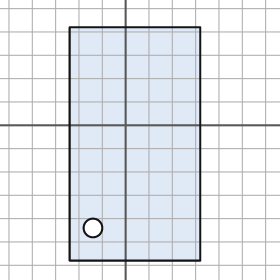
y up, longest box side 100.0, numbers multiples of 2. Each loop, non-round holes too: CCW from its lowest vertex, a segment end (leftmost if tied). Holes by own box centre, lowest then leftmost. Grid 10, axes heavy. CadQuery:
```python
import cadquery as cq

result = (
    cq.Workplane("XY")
    .moveTo(-24.0, -58.0)
    .lineTo(32.0, -58.0)
    .lineTo(32.0, 42.0)
    .lineTo(-24.0, 42.0)
    .close()
    .moveTo(-14.0, -44.0)
    .circle(4.0)
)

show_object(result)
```